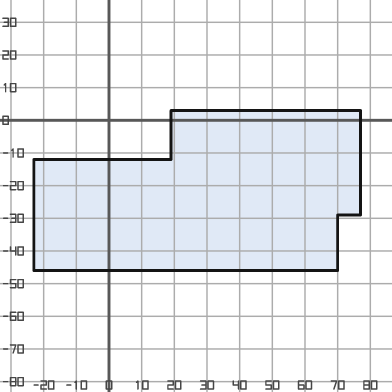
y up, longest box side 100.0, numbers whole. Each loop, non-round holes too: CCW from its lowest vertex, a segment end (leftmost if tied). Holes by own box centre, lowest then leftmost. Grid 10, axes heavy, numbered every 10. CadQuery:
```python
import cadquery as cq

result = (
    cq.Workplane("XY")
    .moveTo(-23.0, -46.0)
    .lineTo(70.0, -46.0)
    .lineTo(70.0, -29.0)
    .lineTo(77.0, -29.0)
    .lineTo(77.0, 3.0)
    .lineTo(19.0, 3.0)
    .lineTo(19.0, -12.0)
    .lineTo(-23.0, -12.0)
    .close()
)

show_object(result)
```